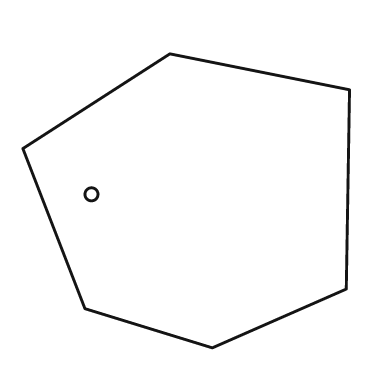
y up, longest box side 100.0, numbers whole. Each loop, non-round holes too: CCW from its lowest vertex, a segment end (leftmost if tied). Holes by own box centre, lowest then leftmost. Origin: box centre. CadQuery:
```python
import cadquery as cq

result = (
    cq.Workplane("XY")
    .moveTo(8.0, -45.0)
    .lineTo(49.0, -27.0)
    .lineTo(50.0, 34.0)
    .lineTo(-5.0, 45.0)
    .lineTo(-50.0, 16.0)
    .lineTo(-31.0, -33.0)
    .close()
    .moveTo(-29.0, 2.0)
    .circle(2.0)
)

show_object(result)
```